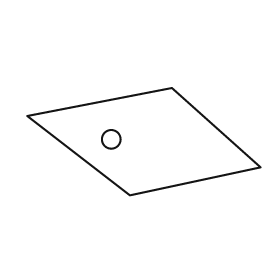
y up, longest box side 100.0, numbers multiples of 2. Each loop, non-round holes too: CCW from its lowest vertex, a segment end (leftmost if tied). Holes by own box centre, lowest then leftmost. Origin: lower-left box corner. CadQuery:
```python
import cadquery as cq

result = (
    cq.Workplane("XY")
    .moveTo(44.0, 0.0)
    .lineTo(100.0, 12.0)
    .lineTo(62.0, 46.0)
    .lineTo(0.0, 34.0)
    .close()
    .moveTo(36.0, 24.0)
    .circle(4.0)
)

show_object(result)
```